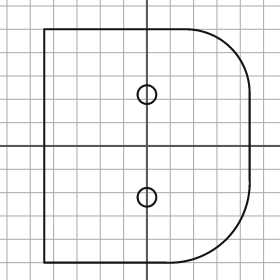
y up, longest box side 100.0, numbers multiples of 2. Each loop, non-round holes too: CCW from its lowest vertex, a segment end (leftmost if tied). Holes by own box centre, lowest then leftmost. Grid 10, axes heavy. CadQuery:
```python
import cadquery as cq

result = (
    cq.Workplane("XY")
    .moveTo(-44.0, -50.0)
    .lineTo(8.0, -50.0)
    .threePointArc((34.0, -40.0), (44.0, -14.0))
    .lineTo(44.0, 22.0)
    .threePointArc((36.0, 42.0), (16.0, 50.0))
    .lineTo(-44.0, 50.0)
    .close()
    .moveTo(0.0, -22.0)
    .circle(4.0)
    .moveTo(0.0, 22.0)
    .circle(4.0)
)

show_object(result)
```